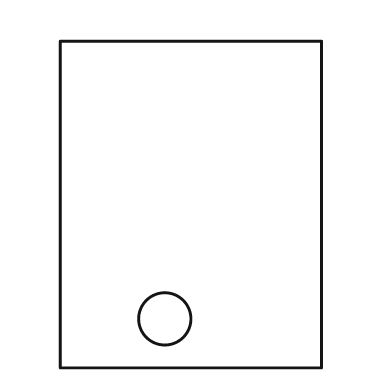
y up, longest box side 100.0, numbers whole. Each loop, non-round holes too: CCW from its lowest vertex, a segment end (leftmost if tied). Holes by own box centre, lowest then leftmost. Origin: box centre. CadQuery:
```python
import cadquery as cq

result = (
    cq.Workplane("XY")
    .moveTo(-40.0, -50.0)
    .lineTo(40.0, -50.0)
    .lineTo(40.0, 50.0)
    .lineTo(-40.0, 50.0)
    .close()
    .moveTo(-8.0, -35.0)
    .circle(8.0)
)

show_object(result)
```